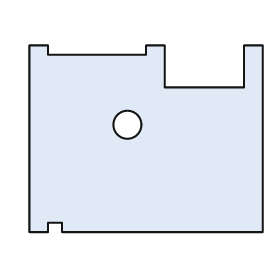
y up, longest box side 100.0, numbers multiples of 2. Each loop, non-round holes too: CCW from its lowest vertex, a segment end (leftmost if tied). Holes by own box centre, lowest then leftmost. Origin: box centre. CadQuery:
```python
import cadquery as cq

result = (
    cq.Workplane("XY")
    .moveTo(-50.0, -40.0)
    .lineTo(-42.0, -40.0)
    .lineTo(-42.0, -36.0)
    .lineTo(-36.0, -36.0)
    .lineTo(-36.0, -40.0)
    .lineTo(50.0, -40.0)
    .lineTo(50.0, 40.0)
    .lineTo(42.0, 40.0)
    .lineTo(42.0, 22.0)
    .lineTo(8.0, 22.0)
    .lineTo(8.0, 40.0)
    .lineTo(0.0, 40.0)
    .lineTo(0.0, 36.0)
    .lineTo(-42.0, 36.0)
    .lineTo(-42.0, 40.0)
    .lineTo(-50.0, 40.0)
    .close()
    .moveTo(-8.0, 6.0)
    .circle(6.0)
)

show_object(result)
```